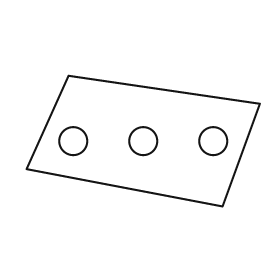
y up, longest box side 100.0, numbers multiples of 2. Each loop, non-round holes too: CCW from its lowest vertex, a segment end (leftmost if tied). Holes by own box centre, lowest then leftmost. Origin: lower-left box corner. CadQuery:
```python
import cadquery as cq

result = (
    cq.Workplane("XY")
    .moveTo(84.0, 0.0)
    .lineTo(100.0, 44.0)
    .lineTo(18.0, 56.0)
    .lineTo(0.0, 16.0)
    .close()
    .moveTo(20.0, 28.0)
    .circle(6.0)
    .moveTo(50.0, 28.0)
    .circle(6.0)
    .moveTo(80.0, 28.0)
    .circle(6.0)
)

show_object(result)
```